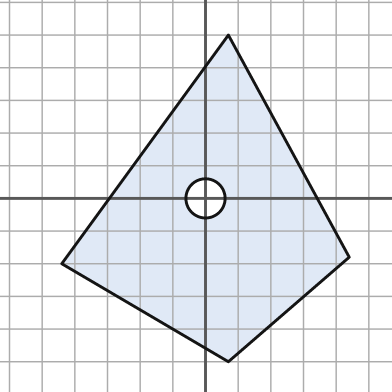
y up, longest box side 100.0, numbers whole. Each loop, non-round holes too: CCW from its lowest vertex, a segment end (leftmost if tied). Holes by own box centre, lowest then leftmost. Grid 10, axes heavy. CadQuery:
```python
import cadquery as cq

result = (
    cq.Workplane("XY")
    .moveTo(7.0, -50.0)
    .lineTo(44.0, -18.0)
    .lineTo(7.0, 50.0)
    .lineTo(-44.0, -20.0)
    .close()
    .moveTo(0.0, 0.0)
    .circle(6.0)
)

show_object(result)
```